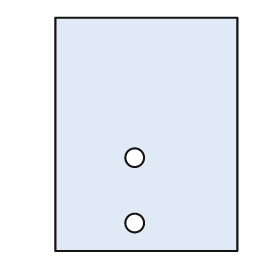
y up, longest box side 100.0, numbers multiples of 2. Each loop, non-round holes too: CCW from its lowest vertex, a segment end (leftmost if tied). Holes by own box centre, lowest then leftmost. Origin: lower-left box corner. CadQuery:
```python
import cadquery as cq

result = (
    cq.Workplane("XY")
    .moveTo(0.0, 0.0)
    .lineTo(78.0, 0.0)
    .lineTo(78.0, 100.0)
    .lineTo(0.0, 100.0)
    .close()
    .moveTo(34.0, 12.0)
    .circle(4.0)
    .moveTo(34.0, 40.0)
    .circle(4.0)
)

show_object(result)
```